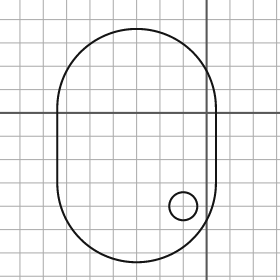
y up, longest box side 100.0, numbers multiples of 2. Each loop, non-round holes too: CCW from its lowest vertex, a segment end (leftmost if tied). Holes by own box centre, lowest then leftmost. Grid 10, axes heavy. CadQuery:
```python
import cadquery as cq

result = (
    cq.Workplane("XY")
    .moveTo(-64.0, -30.0)
    .threePointArc((-30.0, -64.0), (4.0, -30.0))
    .lineTo(4.0, 2.0)
    .threePointArc((-30.0, 36.0), (-64.0, 2.0))
    .close()
    .moveTo(-10.0, -40.0)
    .circle(6.0)
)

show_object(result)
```